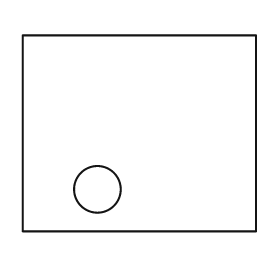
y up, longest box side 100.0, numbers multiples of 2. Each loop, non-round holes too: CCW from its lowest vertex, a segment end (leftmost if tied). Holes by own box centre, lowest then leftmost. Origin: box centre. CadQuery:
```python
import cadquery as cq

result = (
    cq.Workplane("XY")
    .moveTo(-50.0, -42.0)
    .lineTo(50.0, -42.0)
    .lineTo(50.0, 42.0)
    .lineTo(-50.0, 42.0)
    .close()
    .moveTo(-18.0, -24.0)
    .circle(10.0)
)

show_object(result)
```